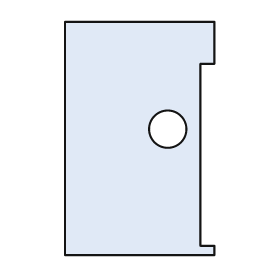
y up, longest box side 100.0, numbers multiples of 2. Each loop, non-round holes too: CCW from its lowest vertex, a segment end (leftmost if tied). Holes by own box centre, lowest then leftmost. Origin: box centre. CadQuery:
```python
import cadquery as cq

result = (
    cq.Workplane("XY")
    .moveTo(-32.0, -50.0)
    .lineTo(32.0, -50.0)
    .lineTo(32.0, -46.0)
    .lineTo(26.0, -46.0)
    .lineTo(26.0, 32.0)
    .lineTo(32.0, 32.0)
    .lineTo(32.0, 50.0)
    .lineTo(-32.0, 50.0)
    .close()
    .moveTo(12.0, 4.0)
    .circle(8.0)
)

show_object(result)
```